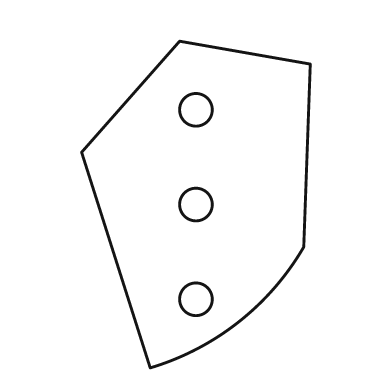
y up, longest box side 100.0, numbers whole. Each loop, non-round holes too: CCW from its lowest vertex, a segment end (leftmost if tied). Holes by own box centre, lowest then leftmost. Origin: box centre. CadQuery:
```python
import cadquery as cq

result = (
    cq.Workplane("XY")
    .moveTo(-14.0, -50.0)
    .threePointArc((13.0, -36.0), (33.0, -13.0))
    .lineTo(35.0, 43.0)
    .lineTo(-5.0, 50.0)
    .lineTo(-35.0, 16.0)
    .close()
    .moveTo(0.0, -29.0)
    .circle(5.0)
    .moveTo(0.0, 0.0)
    .circle(5.0)
    .moveTo(0.0, 29.0)
    .circle(5.0)
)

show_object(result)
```